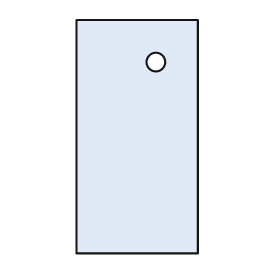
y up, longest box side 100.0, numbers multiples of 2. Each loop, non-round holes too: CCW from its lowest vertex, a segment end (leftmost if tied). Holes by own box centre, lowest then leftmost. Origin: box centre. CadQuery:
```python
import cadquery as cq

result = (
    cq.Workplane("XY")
    .moveTo(-26.0, -50.0)
    .lineTo(26.0, -50.0)
    .lineTo(26.0, 50.0)
    .lineTo(-26.0, 50.0)
    .close()
    .moveTo(8.0, 32.0)
    .circle(4.0)
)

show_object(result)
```